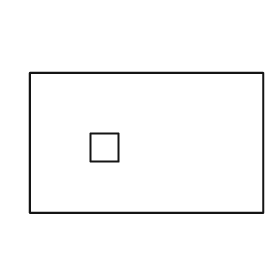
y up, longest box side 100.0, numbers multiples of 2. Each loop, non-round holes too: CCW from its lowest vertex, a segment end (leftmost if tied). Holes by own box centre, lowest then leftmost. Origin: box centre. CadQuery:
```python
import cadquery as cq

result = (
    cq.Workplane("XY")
    .moveTo(-50.0, -30.0)
    .lineTo(50.0, -30.0)
    .lineTo(50.0, 30.0)
    .lineTo(-50.0, 30.0)
    .close()
    .moveTo(-24.0, -8.0)
    .lineTo(-12.0, -8.0)
    .lineTo(-12.0, 4.0)
    .lineTo(-24.0, 4.0)
    .close()
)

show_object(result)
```